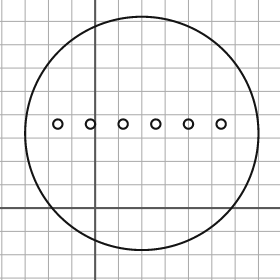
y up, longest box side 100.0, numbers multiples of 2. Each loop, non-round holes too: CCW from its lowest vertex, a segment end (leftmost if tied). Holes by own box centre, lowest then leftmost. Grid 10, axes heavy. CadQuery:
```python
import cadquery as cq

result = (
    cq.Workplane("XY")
    .moveTo(20.0, 32.0)
    .circle(50.0)
    .moveTo(-16.0, 36.0)
    .circle(2.0)
    .moveTo(-2.0, 36.0)
    .circle(2.0)
    .moveTo(12.0, 36.0)
    .circle(2.0)
    .moveTo(26.0, 36.0)
    .circle(2.0)
    .moveTo(40.0, 36.0)
    .circle(2.0)
    .moveTo(54.0, 36.0)
    .circle(2.0)
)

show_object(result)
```